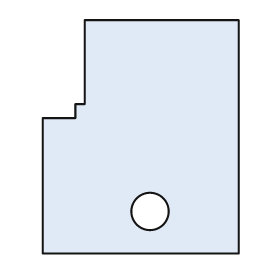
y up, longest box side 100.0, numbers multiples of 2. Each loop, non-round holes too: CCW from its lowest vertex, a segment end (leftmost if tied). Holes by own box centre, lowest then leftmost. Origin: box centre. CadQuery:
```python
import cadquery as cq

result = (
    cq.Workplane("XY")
    .moveTo(-42.0, -50.0)
    .lineTo(42.0, -50.0)
    .lineTo(42.0, 50.0)
    .lineTo(-24.0, 50.0)
    .lineTo(-24.0, 14.0)
    .lineTo(-28.0, 14.0)
    .lineTo(-28.0, 8.0)
    .lineTo(-42.0, 8.0)
    .close()
    .moveTo(4.0, -32.0)
    .circle(8.0)
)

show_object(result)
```